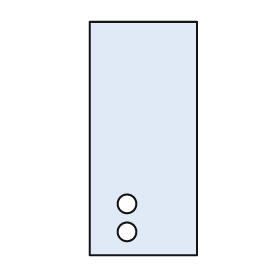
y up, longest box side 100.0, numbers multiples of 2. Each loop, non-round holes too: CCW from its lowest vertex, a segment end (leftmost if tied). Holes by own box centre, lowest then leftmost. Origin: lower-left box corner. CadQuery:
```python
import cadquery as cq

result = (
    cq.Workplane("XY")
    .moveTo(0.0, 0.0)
    .lineTo(46.0, 0.0)
    .lineTo(46.0, 100.0)
    .lineTo(0.0, 100.0)
    .close()
    .moveTo(16.0, 10.0)
    .circle(4.0)
    .moveTo(16.0, 22.0)
    .circle(4.0)
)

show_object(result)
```